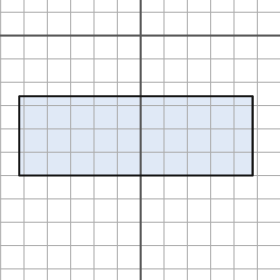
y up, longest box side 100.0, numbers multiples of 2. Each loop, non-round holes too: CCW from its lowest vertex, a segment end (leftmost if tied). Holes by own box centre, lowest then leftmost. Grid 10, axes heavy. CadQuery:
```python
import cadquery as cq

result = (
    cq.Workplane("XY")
    .moveTo(-52.0, -60.0)
    .lineTo(48.0, -60.0)
    .lineTo(48.0, -26.0)
    .lineTo(-52.0, -26.0)
    .close()
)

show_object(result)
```